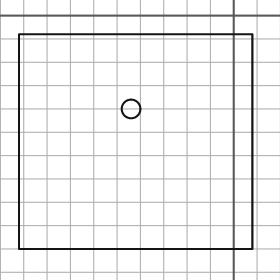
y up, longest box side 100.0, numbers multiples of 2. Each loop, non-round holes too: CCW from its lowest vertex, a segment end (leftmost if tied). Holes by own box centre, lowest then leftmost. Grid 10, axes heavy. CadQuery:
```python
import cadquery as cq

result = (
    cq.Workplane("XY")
    .moveTo(-92.0, -100.0)
    .lineTo(8.0, -100.0)
    .lineTo(8.0, -8.0)
    .lineTo(-92.0, -8.0)
    .close()
    .moveTo(-44.0, -40.0)
    .circle(4.0)
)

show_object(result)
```